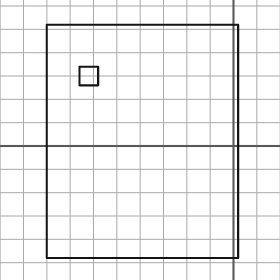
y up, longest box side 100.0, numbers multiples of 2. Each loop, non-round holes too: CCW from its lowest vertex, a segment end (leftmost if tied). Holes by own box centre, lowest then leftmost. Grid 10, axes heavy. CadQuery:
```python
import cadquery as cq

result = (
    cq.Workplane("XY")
    .moveTo(-80.0, -48.0)
    .lineTo(2.0, -48.0)
    .lineTo(2.0, 52.0)
    .lineTo(-80.0, 52.0)
    .close()
    .moveTo(-66.0, 26.0)
    .lineTo(-58.0, 26.0)
    .lineTo(-58.0, 34.0)
    .lineTo(-66.0, 34.0)
    .close()
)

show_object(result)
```